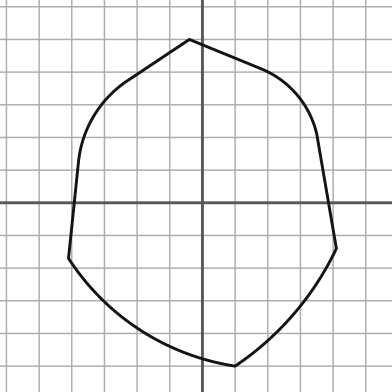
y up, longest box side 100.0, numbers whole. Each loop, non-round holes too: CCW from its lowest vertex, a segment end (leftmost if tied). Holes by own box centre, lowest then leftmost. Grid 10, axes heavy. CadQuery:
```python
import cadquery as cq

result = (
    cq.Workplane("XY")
    .moveTo(10.0, -50.0)
    .threePointArc((28.0, -34.0), (41.0, -14.0))
    .lineTo(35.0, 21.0)
    .threePointArc((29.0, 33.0), (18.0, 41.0))
    .lineTo(-4.0, 50.0)
    .lineTo(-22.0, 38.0)
    .threePointArc((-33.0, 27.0), (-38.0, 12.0))
    .lineTo(-41.0, -17.0)
    .threePointArc((-19.0, -39.0), (10.0, -50.0))
    .close()
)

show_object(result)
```